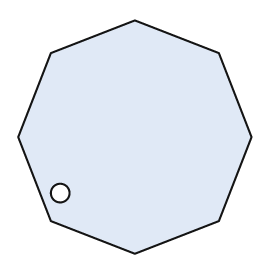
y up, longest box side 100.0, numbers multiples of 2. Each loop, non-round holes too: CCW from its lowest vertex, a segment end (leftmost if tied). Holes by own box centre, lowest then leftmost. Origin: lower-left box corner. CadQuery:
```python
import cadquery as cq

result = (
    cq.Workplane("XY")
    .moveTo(50.0, 0.0)
    .lineTo(86.0, 14.0)
    .lineTo(100.0, 50.0)
    .lineTo(86.0, 86.0)
    .lineTo(50.0, 100.0)
    .lineTo(14.0, 86.0)
    .lineTo(0.0, 50.0)
    .lineTo(14.0, 14.0)
    .close()
    .moveTo(18.0, 26.0)
    .circle(4.0)
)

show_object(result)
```